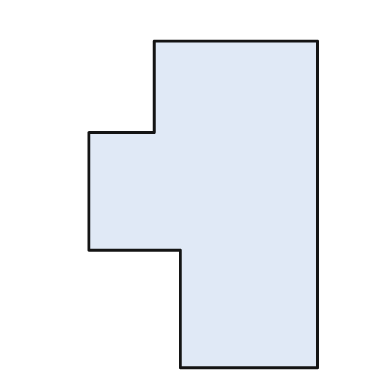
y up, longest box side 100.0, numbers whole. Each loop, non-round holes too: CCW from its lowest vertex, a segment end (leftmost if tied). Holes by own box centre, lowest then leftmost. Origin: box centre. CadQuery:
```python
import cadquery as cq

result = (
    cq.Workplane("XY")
    .moveTo(-7.0, -50.0)
    .lineTo(35.0, -50.0)
    .lineTo(35.0, 50.0)
    .lineTo(-15.0, 50.0)
    .lineTo(-15.0, 22.0)
    .lineTo(-35.0, 22.0)
    .lineTo(-35.0, -14.0)
    .lineTo(-7.0, -14.0)
    .close()
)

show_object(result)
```